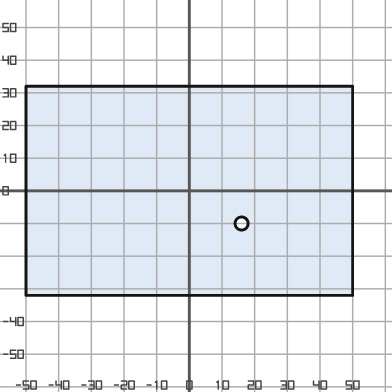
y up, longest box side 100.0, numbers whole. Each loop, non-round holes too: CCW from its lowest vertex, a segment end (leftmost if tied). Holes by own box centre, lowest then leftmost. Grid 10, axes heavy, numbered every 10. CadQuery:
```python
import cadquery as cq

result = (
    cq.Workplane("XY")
    .moveTo(-50.0, -32.0)
    .lineTo(50.0, -32.0)
    .lineTo(50.0, 32.0)
    .lineTo(-50.0, 32.0)
    .close()
    .moveTo(16.0, -10.0)
    .circle(2.0)
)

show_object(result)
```